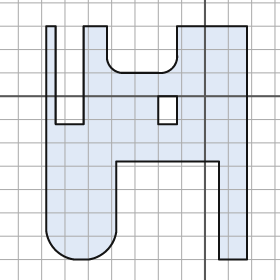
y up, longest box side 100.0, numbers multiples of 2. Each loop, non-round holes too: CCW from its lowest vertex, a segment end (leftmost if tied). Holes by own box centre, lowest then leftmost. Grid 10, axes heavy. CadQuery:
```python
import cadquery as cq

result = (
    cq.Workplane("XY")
    .moveTo(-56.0, -70.0)
    .lineTo(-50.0, -70.0)
    .threePointArc((-42.0, -66.0), (-38.0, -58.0))
    .lineTo(-38.0, -28.0)
    .lineTo(6.0, -28.0)
    .lineTo(6.0, -70.0)
    .lineTo(18.0, -70.0)
    .lineTo(18.0, 30.0)
    .lineTo(-12.0, 30.0)
    .lineTo(-12.0, 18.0)
    .threePointArc((-14.0, 12.0), (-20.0, 10.0))
    .lineTo(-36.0, 10.0)
    .threePointArc((-40.0, 12.0), (-42.0, 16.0))
    .lineTo(-42.0, 30.0)
    .lineTo(-52.0, 30.0)
    .lineTo(-52.0, -12.0)
    .lineTo(-64.0, -12.0)
    .lineTo(-64.0, 30.0)
    .lineTo(-68.0, 30.0)
    .lineTo(-68.0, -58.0)
    .threePointArc((-64.0, -66.0), (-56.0, -70.0))
    .close()
    .moveTo(-20.0, -12.0)
    .lineTo(-12.0, -12.0)
    .lineTo(-12.0, 0.0)
    .lineTo(-20.0, 0.0)
    .close()
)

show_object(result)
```